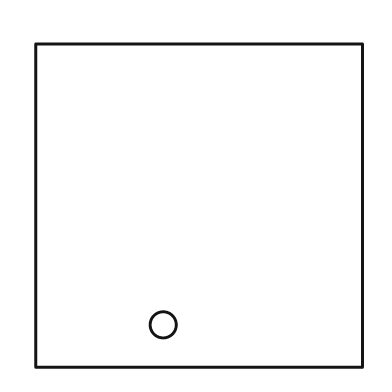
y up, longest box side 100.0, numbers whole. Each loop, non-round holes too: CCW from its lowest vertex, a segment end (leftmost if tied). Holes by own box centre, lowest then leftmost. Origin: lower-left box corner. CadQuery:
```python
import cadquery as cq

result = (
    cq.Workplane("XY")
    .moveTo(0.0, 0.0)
    .lineTo(100.0, 0.0)
    .lineTo(100.0, 99.0)
    .lineTo(0.0, 99.0)
    .close()
    .moveTo(39.0, 13.0)
    .circle(4.0)
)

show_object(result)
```